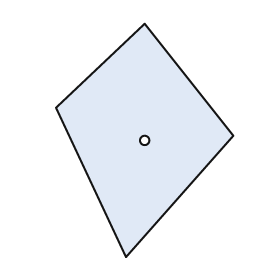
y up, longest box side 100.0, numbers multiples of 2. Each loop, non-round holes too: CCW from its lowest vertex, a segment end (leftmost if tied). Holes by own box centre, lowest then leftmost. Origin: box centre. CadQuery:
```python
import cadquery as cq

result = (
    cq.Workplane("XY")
    .moveTo(-8.0, -50.0)
    .lineTo(38.0, 2.0)
    .lineTo(0.0, 50.0)
    .lineTo(-38.0, 14.0)
    .close()
    .moveTo(0.0, 0.0)
    .circle(2.0)
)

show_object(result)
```